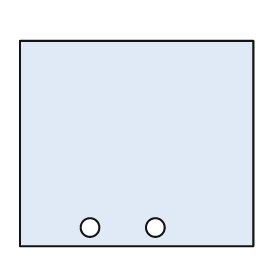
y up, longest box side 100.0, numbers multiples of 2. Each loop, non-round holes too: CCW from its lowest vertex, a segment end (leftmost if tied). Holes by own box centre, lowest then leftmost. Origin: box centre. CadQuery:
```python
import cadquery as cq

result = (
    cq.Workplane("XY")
    .moveTo(-50.0, -44.0)
    .lineTo(50.0, -44.0)
    .lineTo(50.0, 44.0)
    .lineTo(-50.0, 44.0)
    .close()
    .moveTo(-20.0, -36.0)
    .circle(4.0)
    .moveTo(8.0, -36.0)
    .circle(4.0)
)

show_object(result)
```